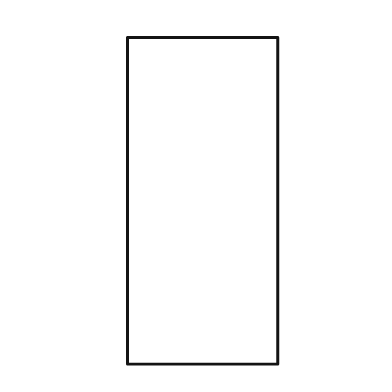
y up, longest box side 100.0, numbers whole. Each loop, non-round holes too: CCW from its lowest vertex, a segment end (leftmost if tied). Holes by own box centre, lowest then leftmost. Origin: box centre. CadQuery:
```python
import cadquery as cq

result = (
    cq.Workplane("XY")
    .moveTo(-23.0, -50.0)
    .lineTo(23.0, -50.0)
    .lineTo(23.0, 50.0)
    .lineTo(-23.0, 50.0)
    .close()
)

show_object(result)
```